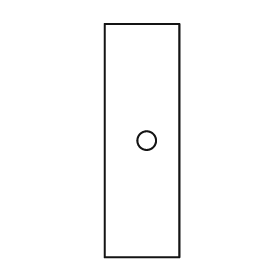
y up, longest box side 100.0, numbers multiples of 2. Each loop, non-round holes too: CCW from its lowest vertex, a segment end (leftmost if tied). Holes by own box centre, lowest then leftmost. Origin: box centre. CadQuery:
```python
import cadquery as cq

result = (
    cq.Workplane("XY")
    .moveTo(-16.0, -50.0)
    .lineTo(16.0, -50.0)
    .lineTo(16.0, 50.0)
    .lineTo(-16.0, 50.0)
    .close()
    .moveTo(2.0, 0.0)
    .circle(4.0)
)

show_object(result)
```